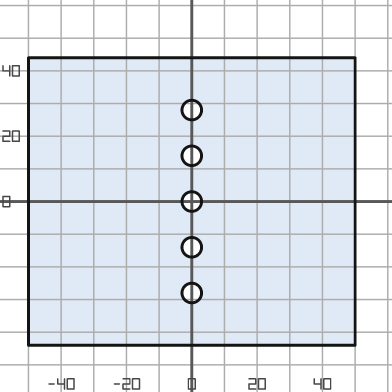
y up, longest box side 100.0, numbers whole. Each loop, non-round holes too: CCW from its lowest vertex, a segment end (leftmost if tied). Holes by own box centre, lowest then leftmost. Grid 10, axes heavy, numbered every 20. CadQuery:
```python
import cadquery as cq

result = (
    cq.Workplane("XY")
    .moveTo(-50.0, -44.0)
    .lineTo(50.0, -44.0)
    .lineTo(50.0, 44.0)
    .lineTo(-50.0, 44.0)
    .close()
    .moveTo(0.0, -28.0)
    .circle(3.0)
    .moveTo(0.0, -14.0)
    .circle(3.0)
    .moveTo(0.0, 0.0)
    .circle(3.0)
    .moveTo(0.0, 14.0)
    .circle(3.0)
    .moveTo(0.0, 28.0)
    .circle(3.0)
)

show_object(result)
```